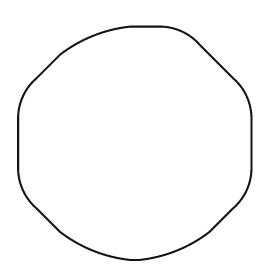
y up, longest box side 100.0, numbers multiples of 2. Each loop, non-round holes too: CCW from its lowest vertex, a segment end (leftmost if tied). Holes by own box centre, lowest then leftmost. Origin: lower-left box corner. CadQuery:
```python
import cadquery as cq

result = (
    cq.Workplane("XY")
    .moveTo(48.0, 0.0)
    .lineTo(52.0, 0.0)
    .threePointArc((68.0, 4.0), (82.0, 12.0))
    .lineTo(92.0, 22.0)
    .threePointArc((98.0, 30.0), (100.0, 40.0))
    .lineTo(100.0, 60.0)
    .threePointArc((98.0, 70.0), (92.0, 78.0))
    .lineTo(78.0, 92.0)
    .threePointArc((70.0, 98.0), (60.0, 100.0))
    .lineTo(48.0, 100.0)
    .threePointArc((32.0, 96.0), (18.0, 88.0))
    .lineTo(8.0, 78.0)
    .threePointArc((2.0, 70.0), (0.0, 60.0))
    .lineTo(0.0, 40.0)
    .threePointArc((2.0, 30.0), (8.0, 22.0))
    .lineTo(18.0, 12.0)
    .threePointArc((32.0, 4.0), (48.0, 0.0))
    .close()
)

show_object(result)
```